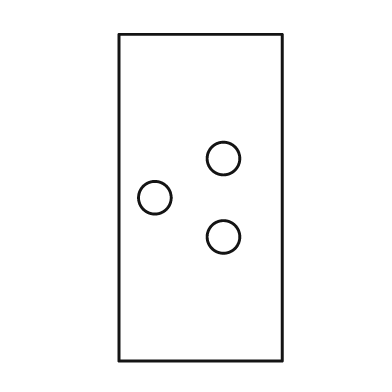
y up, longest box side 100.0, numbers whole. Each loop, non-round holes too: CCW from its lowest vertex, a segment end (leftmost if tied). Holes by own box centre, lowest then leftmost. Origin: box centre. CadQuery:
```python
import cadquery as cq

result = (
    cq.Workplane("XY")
    .moveTo(-25.0, -50.0)
    .lineTo(25.0, -50.0)
    .lineTo(25.0, 50.0)
    .lineTo(-25.0, 50.0)
    .close()
    .moveTo(7.0, -12.0)
    .circle(5.0)
    .moveTo(-14.0, 0.0)
    .circle(5.0)
    .moveTo(7.0, 12.0)
    .circle(5.0)
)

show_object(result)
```